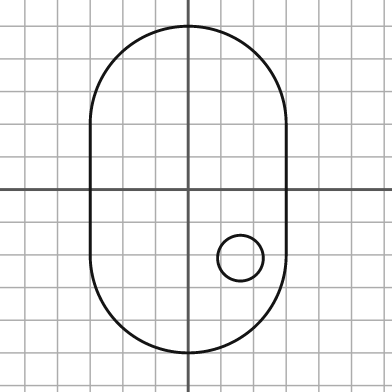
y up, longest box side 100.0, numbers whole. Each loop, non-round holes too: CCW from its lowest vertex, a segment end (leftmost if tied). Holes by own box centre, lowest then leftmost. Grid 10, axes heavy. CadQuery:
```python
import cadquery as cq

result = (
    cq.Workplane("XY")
    .moveTo(-30.0, -20.0)
    .threePointArc((0.0, -50.0), (30.0, -20.0))
    .lineTo(30.0, 20.0)
    .threePointArc((0.0, 50.0), (-30.0, 20.0))
    .close()
    .moveTo(16.0, -21.0)
    .circle(7.0)
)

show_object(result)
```